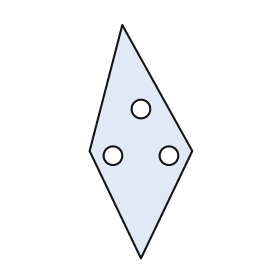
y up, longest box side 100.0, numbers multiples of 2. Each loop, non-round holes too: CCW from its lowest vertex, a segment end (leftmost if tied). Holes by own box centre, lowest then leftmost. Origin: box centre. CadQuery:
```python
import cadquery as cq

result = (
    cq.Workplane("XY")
    .moveTo(0.0, -50.0)
    .lineTo(22.0, -4.0)
    .lineTo(-8.0, 50.0)
    .lineTo(-22.0, -4.0)
    .close()
    .moveTo(-12.0, -6.0)
    .circle(4.0)
    .moveTo(12.0, -6.0)
    .circle(4.0)
    .moveTo(0.0, 14.0)
    .circle(4.0)
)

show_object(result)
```